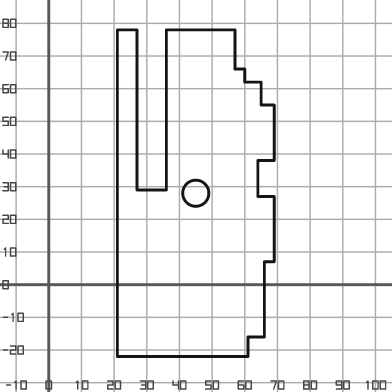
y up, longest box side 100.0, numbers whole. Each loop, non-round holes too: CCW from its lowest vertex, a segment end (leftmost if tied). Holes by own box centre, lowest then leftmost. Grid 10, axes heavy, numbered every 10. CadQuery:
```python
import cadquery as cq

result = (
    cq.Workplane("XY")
    .moveTo(21.0, -22.0)
    .lineTo(61.0, -22.0)
    .lineTo(61.0, -16.0)
    .lineTo(66.0, -16.0)
    .lineTo(66.0, 7.0)
    .lineTo(69.0, 7.0)
    .lineTo(69.0, 27.0)
    .lineTo(64.0, 27.0)
    .lineTo(64.0, 38.0)
    .lineTo(69.0, 38.0)
    .lineTo(69.0, 55.0)
    .lineTo(65.0, 55.0)
    .lineTo(65.0, 62.0)
    .lineTo(60.0, 62.0)
    .lineTo(60.0, 66.0)
    .lineTo(57.0, 66.0)
    .lineTo(57.0, 78.0)
    .lineTo(36.0, 78.0)
    .lineTo(36.0, 29.0)
    .lineTo(27.0, 29.0)
    .lineTo(27.0, 78.0)
    .lineTo(21.0, 78.0)
    .close()
    .moveTo(45.0, 28.0)
    .circle(4.0)
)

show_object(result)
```